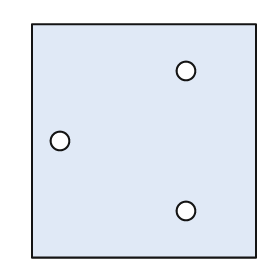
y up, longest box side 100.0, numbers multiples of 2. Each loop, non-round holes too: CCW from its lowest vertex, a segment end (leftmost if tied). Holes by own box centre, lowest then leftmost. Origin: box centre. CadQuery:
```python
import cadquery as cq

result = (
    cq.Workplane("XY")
    .moveTo(-48.0, -50.0)
    .lineTo(48.0, -50.0)
    .lineTo(48.0, 50.0)
    .lineTo(-48.0, 50.0)
    .close()
    .moveTo(18.0, -30.0)
    .circle(4.0)
    .moveTo(-36.0, 0.0)
    .circle(4.0)
    .moveTo(18.0, 30.0)
    .circle(4.0)
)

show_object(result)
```